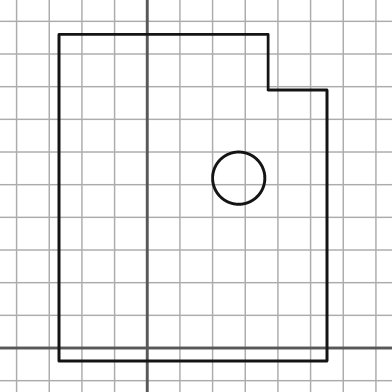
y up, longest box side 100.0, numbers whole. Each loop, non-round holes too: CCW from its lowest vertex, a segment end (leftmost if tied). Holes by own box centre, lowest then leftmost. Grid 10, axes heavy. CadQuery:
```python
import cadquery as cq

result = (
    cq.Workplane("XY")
    .moveTo(-27.0, -4.0)
    .lineTo(55.0, -4.0)
    .lineTo(55.0, 79.0)
    .lineTo(37.0, 79.0)
    .lineTo(37.0, 96.0)
    .lineTo(-27.0, 96.0)
    .close()
    .moveTo(28.0, 52.0)
    .circle(8.0)
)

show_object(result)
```